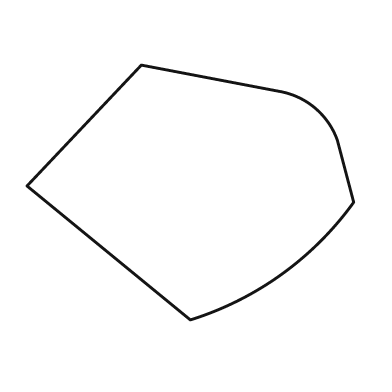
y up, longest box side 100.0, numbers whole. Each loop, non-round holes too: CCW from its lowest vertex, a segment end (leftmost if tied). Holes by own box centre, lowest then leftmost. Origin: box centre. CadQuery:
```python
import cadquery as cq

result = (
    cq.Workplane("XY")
    .moveTo(0.0, -39.0)
    .threePointArc((28.0, -25.0), (50.0, -3.0))
    .lineTo(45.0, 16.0)
    .threePointArc((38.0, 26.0), (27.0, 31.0))
    .lineTo(-15.0, 39.0)
    .lineTo(-50.0, 2.0)
    .close()
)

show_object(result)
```